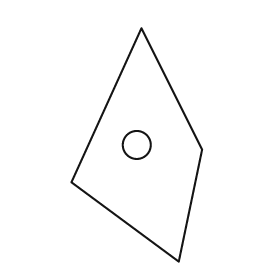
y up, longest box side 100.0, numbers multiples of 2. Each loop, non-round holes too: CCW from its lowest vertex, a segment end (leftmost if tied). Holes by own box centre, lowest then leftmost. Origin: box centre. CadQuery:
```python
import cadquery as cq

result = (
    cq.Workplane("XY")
    .moveTo(18.0, -50.0)
    .lineTo(28.0, -2.0)
    .lineTo(2.0, 50.0)
    .lineTo(-28.0, -16.0)
    .close()
    .moveTo(0.0, 0.0)
    .circle(6.0)
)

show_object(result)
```